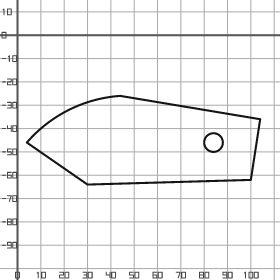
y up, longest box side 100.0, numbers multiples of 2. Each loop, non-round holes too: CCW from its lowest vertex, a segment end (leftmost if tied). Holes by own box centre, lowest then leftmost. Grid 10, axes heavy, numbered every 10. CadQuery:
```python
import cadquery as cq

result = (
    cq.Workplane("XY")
    .moveTo(30.0, -64.0)
    .lineTo(100.0, -62.0)
    .lineTo(104.0, -36.0)
    .lineTo(44.0, -26.0)
    .threePointArc((22.0, -32.0), (4.0, -46.0))
    .close()
    .moveTo(84.0, -46.0)
    .circle(4.0)
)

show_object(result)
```